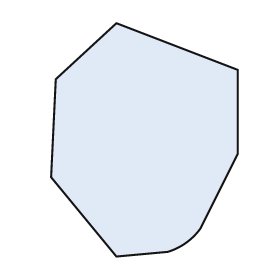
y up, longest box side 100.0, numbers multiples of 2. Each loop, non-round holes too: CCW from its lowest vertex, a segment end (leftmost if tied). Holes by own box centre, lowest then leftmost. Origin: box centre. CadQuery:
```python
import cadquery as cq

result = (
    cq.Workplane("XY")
    .moveTo(-12.0, -50.0)
    .lineTo(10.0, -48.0)
    .threePointArc((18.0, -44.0), (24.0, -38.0))
    .lineTo(40.0, -6.0)
    .lineTo(40.0, 30.0)
    .lineTo(-12.0, 50.0)
    .lineTo(-38.0, 26.0)
    .lineTo(-40.0, -16.0)
    .close()
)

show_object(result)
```